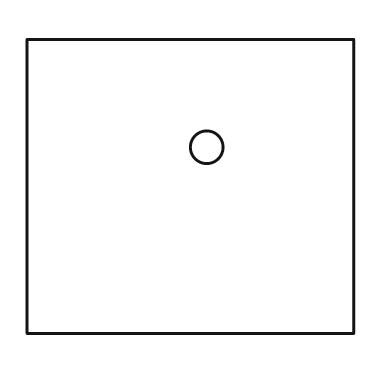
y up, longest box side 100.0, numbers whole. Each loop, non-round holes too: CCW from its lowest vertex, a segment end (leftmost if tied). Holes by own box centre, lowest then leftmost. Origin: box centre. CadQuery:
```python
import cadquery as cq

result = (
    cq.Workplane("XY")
    .moveTo(-50.0, -45.0)
    .lineTo(50.0, -45.0)
    .lineTo(50.0, 45.0)
    .lineTo(-50.0, 45.0)
    .close()
    .moveTo(5.0, 12.0)
    .circle(5.0)
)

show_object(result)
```